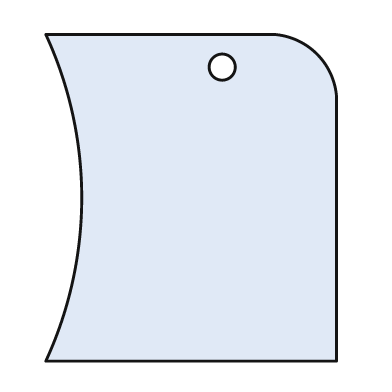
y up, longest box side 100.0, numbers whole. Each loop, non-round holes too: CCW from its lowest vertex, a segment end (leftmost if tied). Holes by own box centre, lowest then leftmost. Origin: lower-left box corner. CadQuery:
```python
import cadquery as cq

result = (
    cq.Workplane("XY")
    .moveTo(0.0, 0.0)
    .lineTo(89.0, 0.0)
    .lineTo(89.0, 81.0)
    .threePointArc((83.0, 94.0), (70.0, 100.0))
    .lineTo(0.0, 100.0)
    .threePointArc((11.0, 50.0), (0.0, 0.0))
    .close()
    .moveTo(54.0, 90.0)
    .circle(4.0)
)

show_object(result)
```